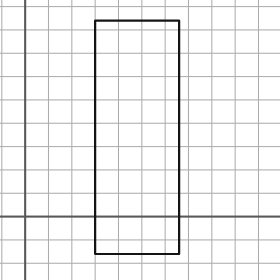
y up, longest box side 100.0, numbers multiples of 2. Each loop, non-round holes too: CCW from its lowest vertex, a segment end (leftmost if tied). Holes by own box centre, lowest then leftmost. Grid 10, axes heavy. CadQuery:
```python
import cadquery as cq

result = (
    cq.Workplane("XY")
    .moveTo(30.0, -16.0)
    .lineTo(66.0, -16.0)
    .lineTo(66.0, 84.0)
    .lineTo(30.0, 84.0)
    .close()
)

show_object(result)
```